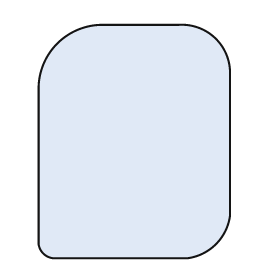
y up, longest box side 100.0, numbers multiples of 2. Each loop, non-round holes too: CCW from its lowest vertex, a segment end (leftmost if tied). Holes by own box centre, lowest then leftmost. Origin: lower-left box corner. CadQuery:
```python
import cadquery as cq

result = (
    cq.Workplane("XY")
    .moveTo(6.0, 0.0)
    .lineTo(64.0, 0.0)
    .threePointArc((76.0, 6.0), (82.0, 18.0))
    .lineTo(82.0, 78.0)
    .threePointArc((76.0, 94.0), (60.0, 100.0))
    .lineTo(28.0, 100.0)
    .threePointArc((8.0, 92.0), (0.0, 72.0))
    .lineTo(0.0, 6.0)
    .threePointArc((2.0, 2.0), (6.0, 0.0))
    .close()
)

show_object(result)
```